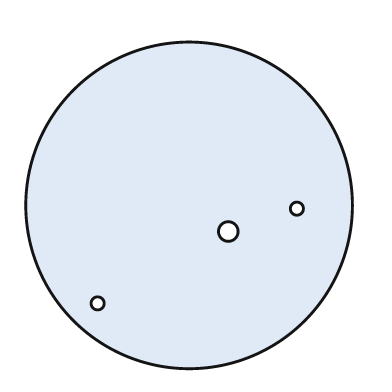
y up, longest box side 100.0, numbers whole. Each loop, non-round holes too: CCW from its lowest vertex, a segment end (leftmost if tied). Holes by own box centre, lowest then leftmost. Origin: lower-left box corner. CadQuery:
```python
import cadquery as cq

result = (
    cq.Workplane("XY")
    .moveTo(50.0, 50.0)
    .circle(50.0)
    .moveTo(22.0, 20.0)
    .circle(2.0)
    .moveTo(62.0, 42.0)
    .circle(3.0)
    .moveTo(83.0, 49.0)
    .circle(2.0)
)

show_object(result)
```